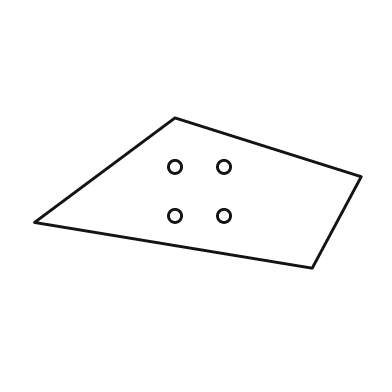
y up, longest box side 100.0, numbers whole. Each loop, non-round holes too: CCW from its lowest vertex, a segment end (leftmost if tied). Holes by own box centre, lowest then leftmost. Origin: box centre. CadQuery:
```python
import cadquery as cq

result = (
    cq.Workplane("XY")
    .moveTo(35.0, -23.0)
    .lineTo(50.0, 5.0)
    .lineTo(-7.0, 23.0)
    .lineTo(-50.0, -9.0)
    .close()
    .moveTo(-7.0, -7.0)
    .circle(2.0)
    .moveTo(8.0, -7.0)
    .circle(2.0)
    .moveTo(-7.0, 8.0)
    .circle(2.0)
    .moveTo(8.0, 8.0)
    .circle(2.0)
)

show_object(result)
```